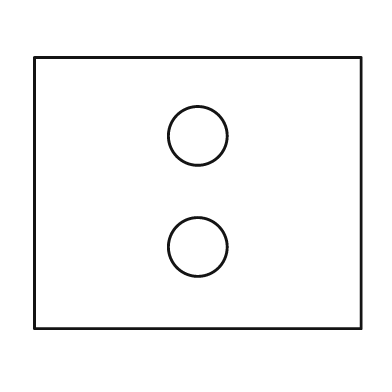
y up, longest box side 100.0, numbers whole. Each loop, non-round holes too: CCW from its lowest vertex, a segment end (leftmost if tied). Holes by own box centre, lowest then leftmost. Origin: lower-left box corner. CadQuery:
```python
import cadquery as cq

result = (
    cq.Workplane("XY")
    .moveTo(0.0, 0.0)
    .lineTo(100.0, 0.0)
    .lineTo(100.0, 83.0)
    .lineTo(0.0, 83.0)
    .close()
    .moveTo(50.0, 25.0)
    .circle(9.0)
    .moveTo(50.0, 59.0)
    .circle(9.0)
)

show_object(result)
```